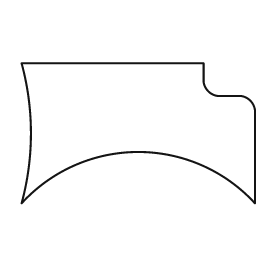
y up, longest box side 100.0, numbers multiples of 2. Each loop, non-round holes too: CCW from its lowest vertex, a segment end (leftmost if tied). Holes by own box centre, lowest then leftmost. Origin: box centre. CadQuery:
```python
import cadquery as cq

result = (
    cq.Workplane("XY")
    .moveTo(-50.0, -30.0)
    .threePointArc((0.0, -8.0), (50.0, -30.0))
    .lineTo(50.0, 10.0)
    .threePointArc((48.0, 14.0), (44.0, 16.0))
    .lineTo(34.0, 16.0)
    .threePointArc((30.0, 18.0), (28.0, 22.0))
    .lineTo(28.0, 30.0)
    .lineTo(-50.0, 30.0)
    .threePointArc((-46.0, 0.0), (-50.0, -30.0))
    .close()
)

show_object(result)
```